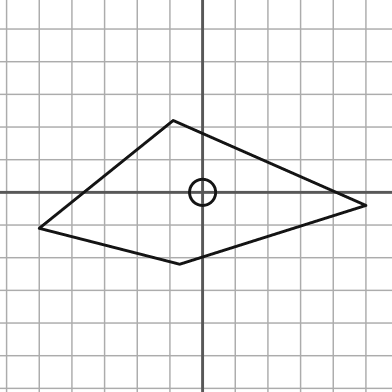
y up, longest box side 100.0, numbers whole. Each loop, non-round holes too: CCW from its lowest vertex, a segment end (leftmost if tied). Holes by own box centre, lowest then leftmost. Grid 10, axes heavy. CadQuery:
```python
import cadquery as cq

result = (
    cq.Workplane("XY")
    .moveTo(-7.0, -22.0)
    .lineTo(50.0, -4.0)
    .lineTo(-9.0, 22.0)
    .lineTo(-50.0, -11.0)
    .close()
    .moveTo(0.0, 0.0)
    .circle(4.0)
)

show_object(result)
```